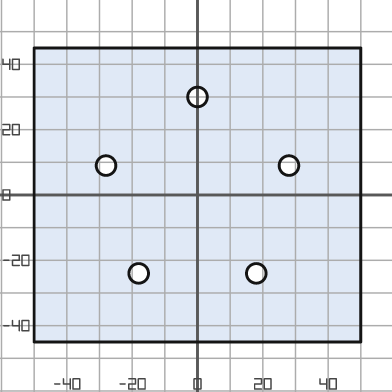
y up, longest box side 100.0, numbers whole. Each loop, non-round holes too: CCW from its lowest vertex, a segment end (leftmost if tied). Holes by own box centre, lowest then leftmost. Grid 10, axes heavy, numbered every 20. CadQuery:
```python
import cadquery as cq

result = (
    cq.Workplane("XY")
    .moveTo(-50.0, -45.0)
    .lineTo(50.0, -45.0)
    .lineTo(50.0, 45.0)
    .lineTo(-50.0, 45.0)
    .close()
    .moveTo(-18.0, -24.0)
    .circle(3.0)
    .moveTo(18.0, -24.0)
    .circle(3.0)
    .moveTo(-28.0, 9.0)
    .circle(3.0)
    .moveTo(28.0, 9.0)
    .circle(3.0)
    .moveTo(0.0, 30.0)
    .circle(3.0)
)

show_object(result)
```